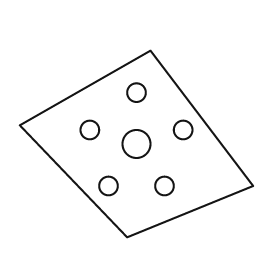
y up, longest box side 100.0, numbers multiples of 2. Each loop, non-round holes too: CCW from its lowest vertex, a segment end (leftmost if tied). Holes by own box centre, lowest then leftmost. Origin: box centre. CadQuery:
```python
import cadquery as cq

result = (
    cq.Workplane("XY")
    .moveTo(-4.0, -40.0)
    .lineTo(50.0, -18.0)
    .lineTo(6.0, 40.0)
    .lineTo(-50.0, 8.0)
    .close()
    .moveTo(-12.0, -18.0)
    .circle(4.0)
    .moveTo(12.0, -18.0)
    .circle(4.0)
    .moveTo(0.0, 0.0)
    .circle(6.0)
    .moveTo(-20.0, 6.0)
    .circle(4.0)
    .moveTo(20.0, 6.0)
    .circle(4.0)
    .moveTo(0.0, 22.0)
    .circle(4.0)
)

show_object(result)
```